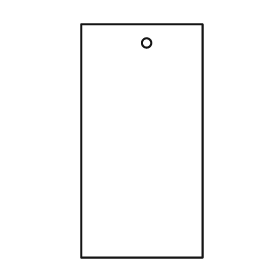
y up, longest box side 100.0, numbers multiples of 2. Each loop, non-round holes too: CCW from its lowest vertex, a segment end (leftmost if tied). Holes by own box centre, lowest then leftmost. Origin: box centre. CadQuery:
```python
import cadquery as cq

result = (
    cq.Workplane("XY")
    .moveTo(-26.0, -50.0)
    .lineTo(26.0, -50.0)
    .lineTo(26.0, 50.0)
    .lineTo(-26.0, 50.0)
    .close()
    .moveTo(2.0, 42.0)
    .circle(2.0)
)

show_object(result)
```